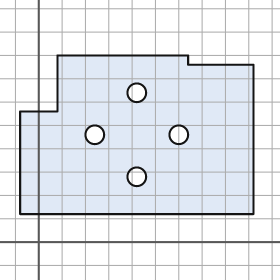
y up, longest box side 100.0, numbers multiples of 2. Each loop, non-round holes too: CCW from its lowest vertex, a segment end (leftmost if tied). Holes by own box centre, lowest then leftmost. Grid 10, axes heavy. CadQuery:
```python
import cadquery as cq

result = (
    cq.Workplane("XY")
    .moveTo(-8.0, 12.0)
    .lineTo(92.0, 12.0)
    .lineTo(92.0, 76.0)
    .lineTo(64.0, 76.0)
    .lineTo(64.0, 80.0)
    .lineTo(8.0, 80.0)
    .lineTo(8.0, 56.0)
    .lineTo(-8.0, 56.0)
    .close()
    .moveTo(42.0, 28.0)
    .circle(4.0)
    .moveTo(24.0, 46.0)
    .circle(4.0)
    .moveTo(60.0, 46.0)
    .circle(4.0)
    .moveTo(42.0, 64.0)
    .circle(4.0)
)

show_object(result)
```